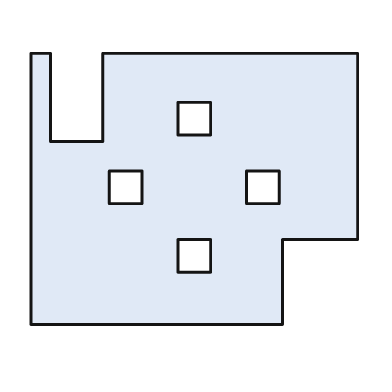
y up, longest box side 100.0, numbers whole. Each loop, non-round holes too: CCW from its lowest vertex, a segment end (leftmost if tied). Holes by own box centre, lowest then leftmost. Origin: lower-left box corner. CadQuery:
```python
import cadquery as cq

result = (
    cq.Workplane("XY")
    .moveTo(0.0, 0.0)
    .lineTo(77.0, 0.0)
    .lineTo(77.0, 26.0)
    .lineTo(100.0, 26.0)
    .lineTo(100.0, 83.0)
    .lineTo(22.0, 83.0)
    .lineTo(22.0, 56.0)
    .lineTo(6.0, 56.0)
    .lineTo(6.0, 83.0)
    .lineTo(0.0, 83.0)
    .close()
    .moveTo(45.0, 16.0)
    .lineTo(55.0, 16.0)
    .lineTo(55.0, 26.0)
    .lineTo(45.0, 26.0)
    .close()
    .moveTo(24.0, 37.0)
    .lineTo(34.0, 37.0)
    .lineTo(34.0, 47.0)
    .lineTo(24.0, 47.0)
    .close()
    .moveTo(66.0, 37.0)
    .lineTo(76.0, 37.0)
    .lineTo(76.0, 47.0)
    .lineTo(66.0, 47.0)
    .close()
    .moveTo(45.0, 58.0)
    .lineTo(55.0, 58.0)
    .lineTo(55.0, 68.0)
    .lineTo(45.0, 68.0)
    .close()
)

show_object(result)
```